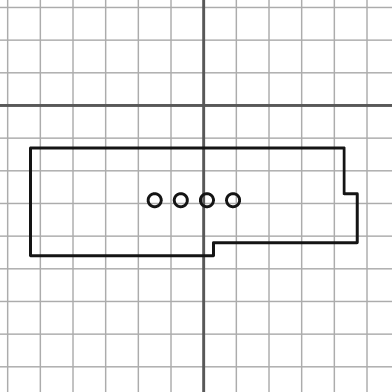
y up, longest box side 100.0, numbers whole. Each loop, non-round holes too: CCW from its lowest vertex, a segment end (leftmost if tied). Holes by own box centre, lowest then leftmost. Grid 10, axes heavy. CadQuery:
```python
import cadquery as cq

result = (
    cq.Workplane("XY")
    .moveTo(-53.0, -46.0)
    .lineTo(3.0, -46.0)
    .lineTo(3.0, -42.0)
    .lineTo(47.0, -42.0)
    .lineTo(47.0, -27.0)
    .lineTo(43.0, -27.0)
    .lineTo(43.0, -13.0)
    .lineTo(-53.0, -13.0)
    .close()
    .moveTo(-15.0, -29.0)
    .circle(2.0)
    .moveTo(-7.0, -29.0)
    .circle(2.0)
    .moveTo(1.0, -29.0)
    .circle(2.0)
    .moveTo(9.0, -29.0)
    .circle(2.0)
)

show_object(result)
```